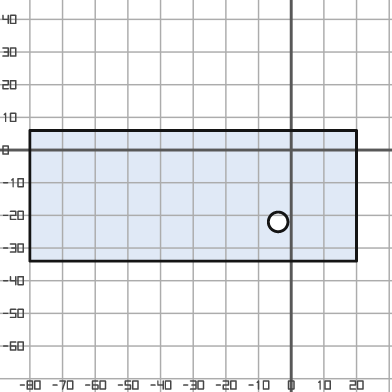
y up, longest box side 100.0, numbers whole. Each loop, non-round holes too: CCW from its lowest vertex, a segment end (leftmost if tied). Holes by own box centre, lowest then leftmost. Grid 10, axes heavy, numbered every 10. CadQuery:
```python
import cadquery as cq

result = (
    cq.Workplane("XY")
    .moveTo(-80.0, -34.0)
    .lineTo(20.0, -34.0)
    .lineTo(20.0, 6.0)
    .lineTo(-80.0, 6.0)
    .close()
    .moveTo(-4.0, -22.0)
    .circle(3.0)
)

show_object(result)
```